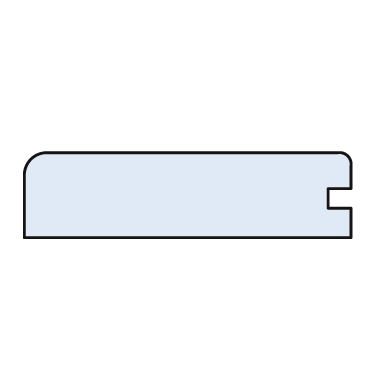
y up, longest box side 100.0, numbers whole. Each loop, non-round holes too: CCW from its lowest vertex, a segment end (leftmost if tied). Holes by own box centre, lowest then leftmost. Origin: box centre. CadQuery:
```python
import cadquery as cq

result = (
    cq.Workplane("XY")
    .moveTo(-50.0, -13.0)
    .lineTo(50.0, -13.0)
    .lineTo(50.0, -4.0)
    .lineTo(43.0, -4.0)
    .lineTo(43.0, 2.0)
    .lineTo(50.0, 2.0)
    .lineTo(50.0, 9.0)
    .threePointArc((49.0, 12.0), (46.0, 13.0))
    .lineTo(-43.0, 13.0)
    .threePointArc((-48.0, 11.0), (-50.0, 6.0))
    .close()
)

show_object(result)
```